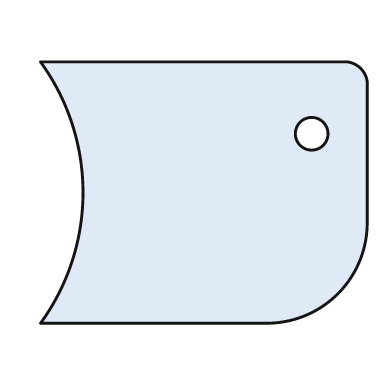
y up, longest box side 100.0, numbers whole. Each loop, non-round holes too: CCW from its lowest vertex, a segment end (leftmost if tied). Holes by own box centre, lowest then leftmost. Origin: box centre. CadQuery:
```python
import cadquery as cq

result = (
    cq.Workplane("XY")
    .moveTo(-50.0, -40.0)
    .lineTo(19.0, -40.0)
    .threePointArc((41.0, -31.0), (50.0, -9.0))
    .lineTo(50.0, 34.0)
    .threePointArc((48.0, 38.0), (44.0, 40.0))
    .lineTo(-50.0, 40.0)
    .threePointArc((-37.0, 0.0), (-50.0, -40.0))
    .close()
    .moveTo(33.0, 18.0)
    .circle(5.0)
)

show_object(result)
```